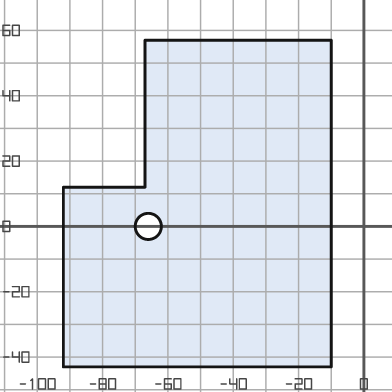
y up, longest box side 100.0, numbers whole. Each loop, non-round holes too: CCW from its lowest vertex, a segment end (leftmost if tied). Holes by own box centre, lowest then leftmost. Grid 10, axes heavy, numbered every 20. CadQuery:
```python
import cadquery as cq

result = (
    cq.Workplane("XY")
    .moveTo(-92.0, -43.0)
    .lineTo(-10.0, -43.0)
    .lineTo(-10.0, 57.0)
    .lineTo(-67.0, 57.0)
    .lineTo(-67.0, 12.0)
    .lineTo(-92.0, 12.0)
    .close()
    .moveTo(-66.0, 0.0)
    .circle(4.0)
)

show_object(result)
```